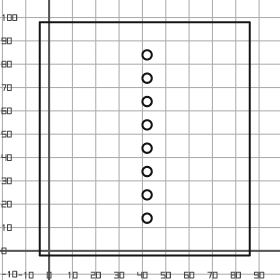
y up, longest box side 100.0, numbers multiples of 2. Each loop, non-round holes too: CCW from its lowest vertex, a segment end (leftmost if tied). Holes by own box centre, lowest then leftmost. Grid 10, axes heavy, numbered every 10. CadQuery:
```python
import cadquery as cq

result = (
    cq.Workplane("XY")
    .moveTo(-4.0, -2.0)
    .lineTo(86.0, -2.0)
    .lineTo(86.0, 98.0)
    .lineTo(-4.0, 98.0)
    .close()
    .moveTo(42.0, 14.0)
    .circle(2.0)
    .moveTo(42.0, 24.0)
    .circle(2.0)
    .moveTo(42.0, 34.0)
    .circle(2.0)
    .moveTo(42.0, 44.0)
    .circle(2.0)
    .moveTo(42.0, 54.0)
    .circle(2.0)
    .moveTo(42.0, 64.0)
    .circle(2.0)
    .moveTo(42.0, 74.0)
    .circle(2.0)
    .moveTo(42.0, 84.0)
    .circle(2.0)
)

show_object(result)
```